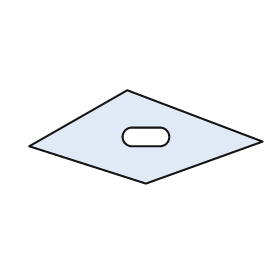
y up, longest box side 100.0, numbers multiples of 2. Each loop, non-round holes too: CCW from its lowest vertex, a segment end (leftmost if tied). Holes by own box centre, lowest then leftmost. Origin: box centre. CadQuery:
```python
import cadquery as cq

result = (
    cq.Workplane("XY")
    .moveTo(0.0, -20.0)
    .lineTo(50.0, -2.0)
    .lineTo(-8.0, 20.0)
    .lineTo(-50.0, -4.0)
    .close()
    .moveTo(-6.0, -4.0)
    .lineTo(6.0, -4.0)
    .threePointArc((10.0, 0.0), (6.0, 4.0))
    .lineTo(-6.0, 4.0)
    .threePointArc((-10.0, 0.0), (-6.0, -4.0))
    .close()
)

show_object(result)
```